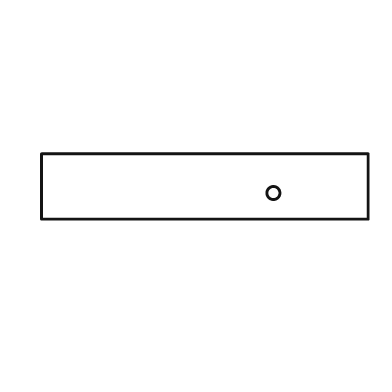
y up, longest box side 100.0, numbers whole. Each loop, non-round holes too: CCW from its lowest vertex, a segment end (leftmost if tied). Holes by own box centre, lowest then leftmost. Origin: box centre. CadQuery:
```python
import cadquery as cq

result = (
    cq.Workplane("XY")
    .moveTo(-50.0, -10.0)
    .lineTo(50.0, -10.0)
    .lineTo(50.0, 10.0)
    .lineTo(-50.0, 10.0)
    .close()
    .moveTo(21.0, -2.0)
    .circle(2.0)
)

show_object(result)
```